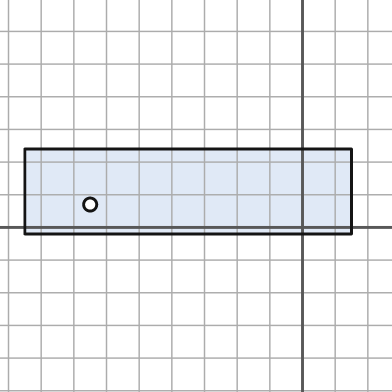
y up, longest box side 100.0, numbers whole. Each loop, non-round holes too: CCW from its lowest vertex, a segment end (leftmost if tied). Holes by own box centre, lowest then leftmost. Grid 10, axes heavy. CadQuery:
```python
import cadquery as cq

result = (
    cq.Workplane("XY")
    .moveTo(-85.0, -2.0)
    .lineTo(15.0, -2.0)
    .lineTo(15.0, 24.0)
    .lineTo(-85.0, 24.0)
    .close()
    .moveTo(-65.0, 7.0)
    .circle(2.0)
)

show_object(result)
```